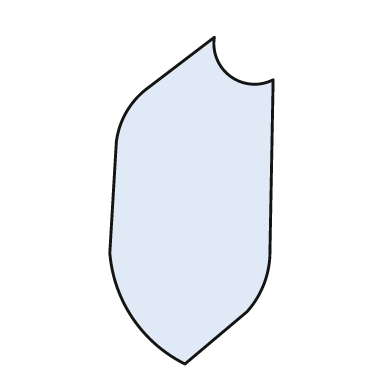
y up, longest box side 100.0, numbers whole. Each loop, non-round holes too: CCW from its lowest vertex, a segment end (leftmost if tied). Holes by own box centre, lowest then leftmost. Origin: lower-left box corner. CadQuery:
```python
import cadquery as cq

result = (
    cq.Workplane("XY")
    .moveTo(23.0, 0.0)
    .lineTo(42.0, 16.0)
    .threePointArc((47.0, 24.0), (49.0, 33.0))
    .lineTo(50.0, 87.0)
    .threePointArc((37.0, 88.0), (32.0, 100.0))
    .lineTo(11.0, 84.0)
    .threePointArc((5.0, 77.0), (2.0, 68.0))
    .lineTo(0.0, 34.0)
    .threePointArc((7.0, 14.0), (23.0, 0.0))
    .close()
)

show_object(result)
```